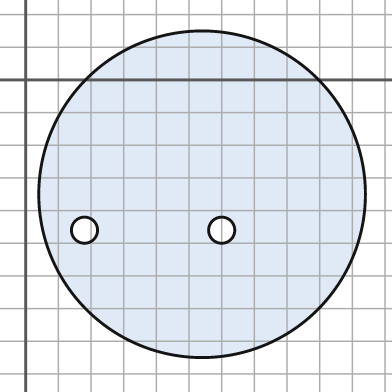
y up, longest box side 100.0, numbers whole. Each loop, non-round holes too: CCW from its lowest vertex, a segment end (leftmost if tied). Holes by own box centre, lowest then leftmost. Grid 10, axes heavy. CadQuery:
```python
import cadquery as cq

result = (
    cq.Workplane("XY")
    .moveTo(54.0, -35.0)
    .circle(50.0)
    .moveTo(18.0, -46.0)
    .circle(4.0)
    .moveTo(60.0, -46.0)
    .circle(4.0)
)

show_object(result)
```